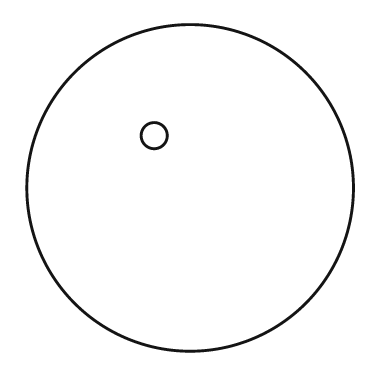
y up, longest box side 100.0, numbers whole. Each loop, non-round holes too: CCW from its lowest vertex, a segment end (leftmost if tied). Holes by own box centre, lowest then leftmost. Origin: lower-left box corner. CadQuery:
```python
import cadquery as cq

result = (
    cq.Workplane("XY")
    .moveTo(50.0, 50.0)
    .circle(50.0)
    .moveTo(39.0, 66.0)
    .circle(4.0)
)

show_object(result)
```